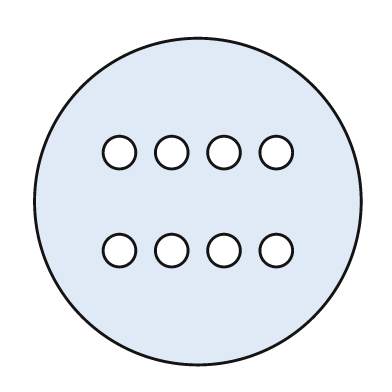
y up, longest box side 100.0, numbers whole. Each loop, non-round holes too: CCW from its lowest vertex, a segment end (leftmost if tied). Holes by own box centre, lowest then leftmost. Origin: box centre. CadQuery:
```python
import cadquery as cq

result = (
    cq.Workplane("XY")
    .moveTo(0.0, 0.0)
    .circle(50.0)
    .moveTo(-24.0, -15.0)
    .circle(5.0)
    .moveTo(-8.0, -15.0)
    .circle(5.0)
    .moveTo(8.0, -15.0)
    .circle(5.0)
    .moveTo(24.0, -15.0)
    .circle(5.0)
    .moveTo(-24.0, 15.0)
    .circle(5.0)
    .moveTo(-8.0, 15.0)
    .circle(5.0)
    .moveTo(8.0, 15.0)
    .circle(5.0)
    .moveTo(24.0, 15.0)
    .circle(5.0)
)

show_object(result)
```